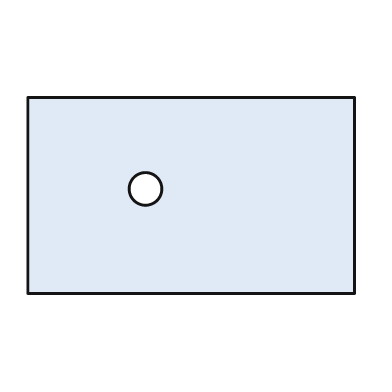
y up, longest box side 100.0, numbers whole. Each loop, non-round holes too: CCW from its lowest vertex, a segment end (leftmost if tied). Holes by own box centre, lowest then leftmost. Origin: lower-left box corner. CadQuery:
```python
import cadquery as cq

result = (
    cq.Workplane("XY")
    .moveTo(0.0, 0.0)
    .lineTo(100.0, 0.0)
    .lineTo(100.0, 60.0)
    .lineTo(0.0, 60.0)
    .close()
    .moveTo(36.0, 32.0)
    .circle(5.0)
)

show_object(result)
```